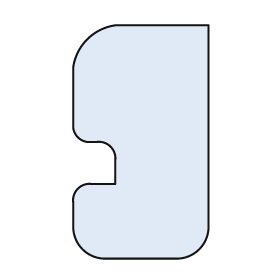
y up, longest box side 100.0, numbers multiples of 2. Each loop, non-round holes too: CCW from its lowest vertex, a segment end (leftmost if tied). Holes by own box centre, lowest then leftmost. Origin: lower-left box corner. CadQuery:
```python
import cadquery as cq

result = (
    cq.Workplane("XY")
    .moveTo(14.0, 0.0)
    .lineTo(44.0, 0.0)
    .threePointArc((54.0, 4.0), (58.0, 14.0))
    .lineTo(58.0, 100.0)
    .lineTo(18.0, 100.0)
    .threePointArc((6.0, 94.0), (0.0, 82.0))
    .lineTo(0.0, 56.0)
    .threePointArc((2.0, 52.0), (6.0, 50.0))
    .lineTo(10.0, 50.0)
    .threePointArc((16.0, 48.0), (18.0, 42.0))
    .lineTo(18.0, 32.0)
    .lineTo(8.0, 32.0)
    .threePointArc((2.0, 30.0), (0.0, 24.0))
    .lineTo(0.0, 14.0)
    .threePointArc((4.0, 4.0), (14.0, 0.0))
    .close()
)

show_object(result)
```